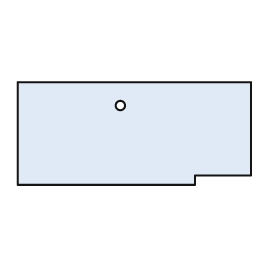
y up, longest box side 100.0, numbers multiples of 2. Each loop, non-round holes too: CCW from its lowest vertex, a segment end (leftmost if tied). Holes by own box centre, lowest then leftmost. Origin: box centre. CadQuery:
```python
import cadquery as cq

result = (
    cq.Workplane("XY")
    .moveTo(-50.0, -22.0)
    .lineTo(26.0, -22.0)
    .lineTo(26.0, -18.0)
    .lineTo(50.0, -18.0)
    .lineTo(50.0, 22.0)
    .lineTo(-50.0, 22.0)
    .close()
    .moveTo(-6.0, 12.0)
    .circle(2.0)
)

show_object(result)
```